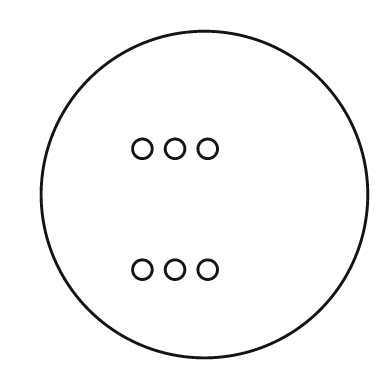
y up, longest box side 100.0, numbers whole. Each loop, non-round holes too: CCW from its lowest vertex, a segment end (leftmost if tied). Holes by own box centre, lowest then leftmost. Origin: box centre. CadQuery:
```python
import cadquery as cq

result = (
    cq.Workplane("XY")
    .moveTo(0.0, 0.0)
    .circle(50.0)
    .moveTo(-19.0, -23.0)
    .circle(3.0)
    .moveTo(-9.0, -23.0)
    .circle(3.0)
    .moveTo(1.0, -23.0)
    .circle(3.0)
    .moveTo(-19.0, 14.0)
    .circle(3.0)
    .moveTo(-9.0, 14.0)
    .circle(3.0)
    .moveTo(1.0, 14.0)
    .circle(3.0)
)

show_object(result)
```